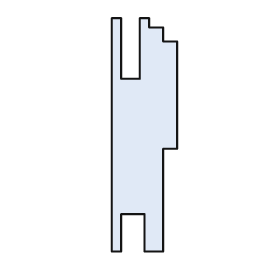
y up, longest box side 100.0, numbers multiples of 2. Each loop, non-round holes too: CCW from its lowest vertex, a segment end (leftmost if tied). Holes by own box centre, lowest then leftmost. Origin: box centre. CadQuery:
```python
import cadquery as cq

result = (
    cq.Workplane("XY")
    .moveTo(-14.0, -50.0)
    .lineTo(-10.0, -50.0)
    .lineTo(-10.0, -34.0)
    .lineTo(0.0, -34.0)
    .lineTo(0.0, -50.0)
    .lineTo(8.0, -50.0)
    .lineTo(8.0, -6.0)
    .lineTo(14.0, -6.0)
    .lineTo(14.0, 40.0)
    .lineTo(8.0, 40.0)
    .lineTo(8.0, 46.0)
    .lineTo(2.0, 46.0)
    .lineTo(2.0, 50.0)
    .lineTo(-2.0, 50.0)
    .lineTo(-2.0, 24.0)
    .lineTo(-10.0, 24.0)
    .lineTo(-10.0, 50.0)
    .lineTo(-14.0, 50.0)
    .close()
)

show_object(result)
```